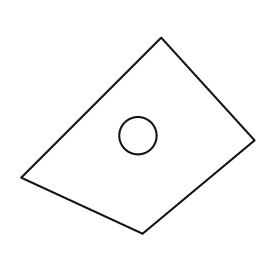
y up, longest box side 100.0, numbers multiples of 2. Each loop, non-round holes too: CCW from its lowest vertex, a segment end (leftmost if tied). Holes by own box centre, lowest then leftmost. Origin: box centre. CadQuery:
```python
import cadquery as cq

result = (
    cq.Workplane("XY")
    .moveTo(2.0, -42.0)
    .lineTo(50.0, -2.0)
    .lineTo(10.0, 42.0)
    .lineTo(-50.0, -18.0)
    .close()
    .moveTo(0.0, 0.0)
    .circle(8.0)
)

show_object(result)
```